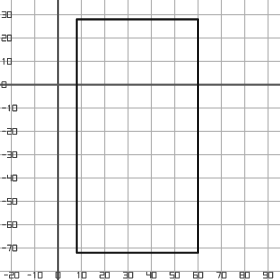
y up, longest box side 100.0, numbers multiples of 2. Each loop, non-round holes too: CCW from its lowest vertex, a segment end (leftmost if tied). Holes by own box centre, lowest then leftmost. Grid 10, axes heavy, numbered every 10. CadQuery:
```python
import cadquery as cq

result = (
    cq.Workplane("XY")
    .moveTo(8.0, -72.0)
    .lineTo(60.0, -72.0)
    .lineTo(60.0, 28.0)
    .lineTo(8.0, 28.0)
    .close()
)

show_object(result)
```